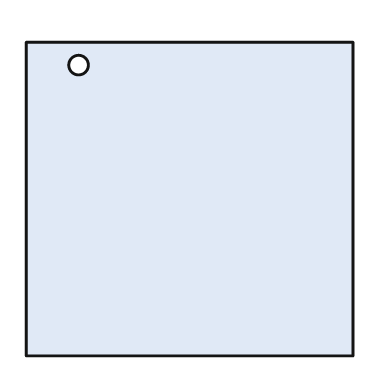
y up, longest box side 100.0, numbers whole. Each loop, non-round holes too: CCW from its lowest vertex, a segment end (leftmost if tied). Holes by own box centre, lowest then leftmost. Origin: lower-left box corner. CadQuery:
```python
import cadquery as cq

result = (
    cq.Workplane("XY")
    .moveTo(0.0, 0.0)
    .lineTo(100.0, 0.0)
    .lineTo(100.0, 96.0)
    .lineTo(0.0, 96.0)
    .close()
    .moveTo(16.0, 89.0)
    .circle(3.0)
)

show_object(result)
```